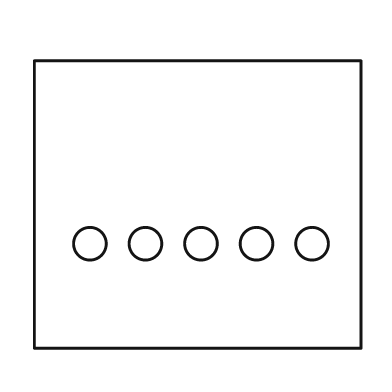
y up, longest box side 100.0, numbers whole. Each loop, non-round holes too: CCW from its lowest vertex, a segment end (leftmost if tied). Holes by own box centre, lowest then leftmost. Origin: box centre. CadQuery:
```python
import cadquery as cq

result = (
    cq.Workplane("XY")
    .moveTo(-50.0, -44.0)
    .lineTo(50.0, -44.0)
    .lineTo(50.0, 44.0)
    .lineTo(-50.0, 44.0)
    .close()
    .moveTo(-33.0, -12.0)
    .circle(5.0)
    .moveTo(-16.0, -12.0)
    .circle(5.0)
    .moveTo(1.0, -12.0)
    .circle(5.0)
    .moveTo(18.0, -12.0)
    .circle(5.0)
    .moveTo(35.0, -12.0)
    .circle(5.0)
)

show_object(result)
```